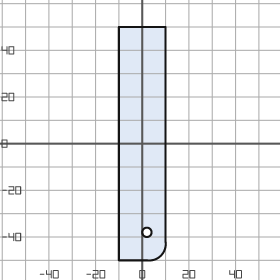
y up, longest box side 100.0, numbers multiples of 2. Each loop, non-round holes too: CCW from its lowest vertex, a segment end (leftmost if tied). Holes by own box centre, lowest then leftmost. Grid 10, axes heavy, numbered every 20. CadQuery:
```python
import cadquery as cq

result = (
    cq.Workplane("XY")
    .moveTo(-10.0, -50.0)
    .lineTo(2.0, -50.0)
    .threePointArc((8.0, -48.0), (10.0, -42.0))
    .lineTo(10.0, 50.0)
    .lineTo(-10.0, 50.0)
    .close()
    .moveTo(2.0, -38.0)
    .circle(2.0)
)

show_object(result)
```